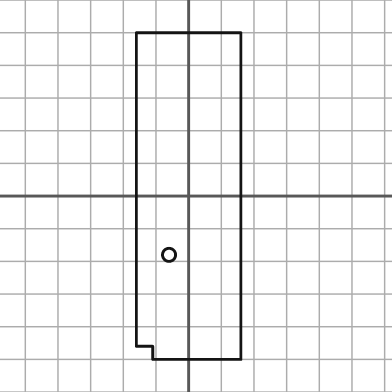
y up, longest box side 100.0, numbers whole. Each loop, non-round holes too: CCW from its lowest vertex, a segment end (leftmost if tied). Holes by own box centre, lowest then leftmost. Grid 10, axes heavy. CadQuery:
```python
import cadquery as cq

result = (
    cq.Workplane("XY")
    .moveTo(-11.0, -50.0)
    .lineTo(16.0, -50.0)
    .lineTo(16.0, 50.0)
    .lineTo(-16.0, 50.0)
    .lineTo(-16.0, -46.0)
    .lineTo(-11.0, -46.0)
    .close()
    .moveTo(-6.0, -18.0)
    .circle(2.0)
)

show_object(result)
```